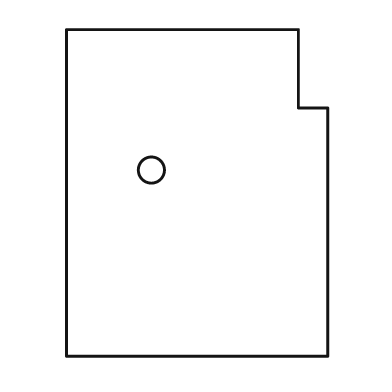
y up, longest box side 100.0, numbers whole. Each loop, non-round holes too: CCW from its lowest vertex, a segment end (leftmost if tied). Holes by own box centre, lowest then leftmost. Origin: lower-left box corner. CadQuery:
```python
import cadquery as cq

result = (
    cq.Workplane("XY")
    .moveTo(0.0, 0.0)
    .lineTo(80.0, 0.0)
    .lineTo(80.0, 76.0)
    .lineTo(71.0, 76.0)
    .lineTo(71.0, 100.0)
    .lineTo(0.0, 100.0)
    .close()
    .moveTo(26.0, 57.0)
    .circle(4.0)
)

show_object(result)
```